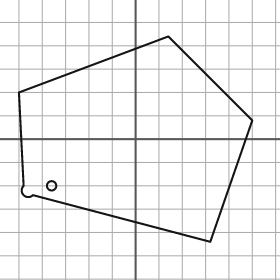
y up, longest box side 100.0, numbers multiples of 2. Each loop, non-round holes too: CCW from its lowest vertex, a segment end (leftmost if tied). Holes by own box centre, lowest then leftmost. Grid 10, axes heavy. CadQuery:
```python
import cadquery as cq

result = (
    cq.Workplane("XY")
    .moveTo(32.0, -44.0)
    .lineTo(50.0, 8.0)
    .lineTo(14.0, 44.0)
    .lineTo(-50.0, 20.0)
    .lineTo(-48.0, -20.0)
    .threePointArc((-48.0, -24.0), (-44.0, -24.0))
    .close()
    .moveTo(-36.0, -20.0)
    .circle(2.0)
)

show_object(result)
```